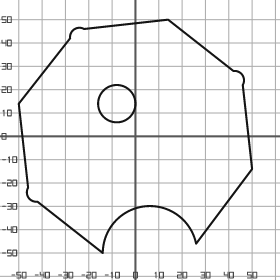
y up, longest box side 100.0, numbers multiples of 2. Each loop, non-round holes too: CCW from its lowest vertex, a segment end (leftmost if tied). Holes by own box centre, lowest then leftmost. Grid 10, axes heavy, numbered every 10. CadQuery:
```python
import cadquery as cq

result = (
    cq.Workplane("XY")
    .moveTo(-14.0, -50.0)
    .threePointArc((4.0, -30.0), (26.0, -46.0))
    .lineTo(50.0, -14.0)
    .lineTo(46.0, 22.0)
    .threePointArc((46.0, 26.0), (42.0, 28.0))
    .lineTo(14.0, 50.0)
    .lineTo(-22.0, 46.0)
    .threePointArc((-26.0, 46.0), (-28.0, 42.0))
    .lineTo(-50.0, 14.0)
    .lineTo(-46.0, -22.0)
    .threePointArc((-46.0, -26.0), (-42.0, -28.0))
    .close()
    .moveTo(-8.0, 14.0)
    .circle(8.0)
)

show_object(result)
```